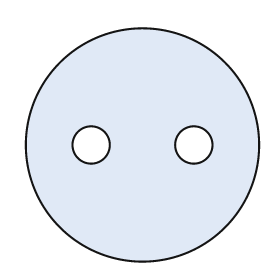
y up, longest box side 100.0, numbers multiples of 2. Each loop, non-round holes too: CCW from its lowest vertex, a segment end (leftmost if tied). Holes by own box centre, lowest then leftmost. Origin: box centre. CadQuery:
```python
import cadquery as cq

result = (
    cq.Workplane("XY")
    .moveTo(0.0, 0.0)
    .circle(50.0)
    .moveTo(-22.0, 0.0)
    .circle(8.0)
    .moveTo(22.0, 0.0)
    .circle(8.0)
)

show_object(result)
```